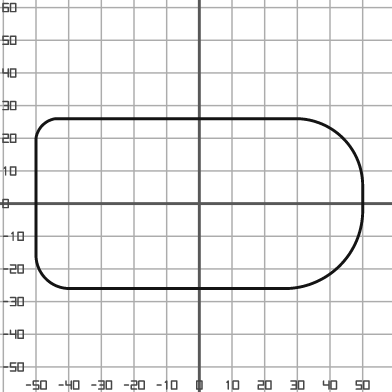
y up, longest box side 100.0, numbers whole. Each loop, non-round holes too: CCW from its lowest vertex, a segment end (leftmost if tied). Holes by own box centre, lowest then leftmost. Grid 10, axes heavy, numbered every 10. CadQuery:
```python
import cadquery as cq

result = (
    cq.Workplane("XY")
    .moveTo(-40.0, -26.0)
    .lineTo(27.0, -26.0)
    .threePointArc((43.0, -19.0), (50.0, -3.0))
    .lineTo(50.0, 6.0)
    .threePointArc((44.0, 20.0), (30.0, 26.0))
    .lineTo(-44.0, 26.0)
    .threePointArc((-48.0, 24.0), (-50.0, 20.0))
    .lineTo(-50.0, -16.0)
    .threePointArc((-47.0, -23.0), (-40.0, -26.0))
    .close()
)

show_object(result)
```